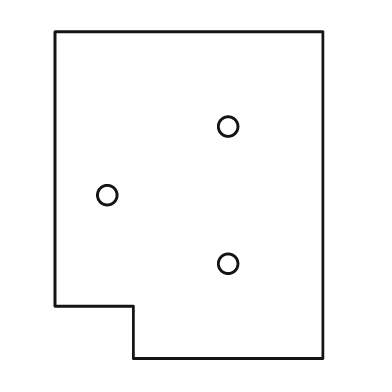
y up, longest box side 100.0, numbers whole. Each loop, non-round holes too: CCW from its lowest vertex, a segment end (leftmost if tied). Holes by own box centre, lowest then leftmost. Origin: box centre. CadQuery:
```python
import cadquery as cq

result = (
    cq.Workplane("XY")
    .moveTo(-17.0, -50.0)
    .lineTo(41.0, -50.0)
    .lineTo(41.0, 50.0)
    .lineTo(-41.0, 50.0)
    .lineTo(-41.0, -34.0)
    .lineTo(-17.0, -34.0)
    .close()
    .moveTo(12.0, -21.0)
    .circle(3.0)
    .moveTo(-25.0, 0.0)
    .circle(3.0)
    .moveTo(12.0, 21.0)
    .circle(3.0)
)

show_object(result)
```